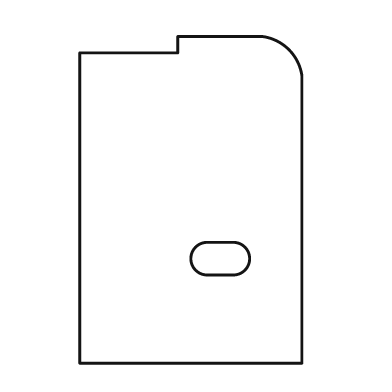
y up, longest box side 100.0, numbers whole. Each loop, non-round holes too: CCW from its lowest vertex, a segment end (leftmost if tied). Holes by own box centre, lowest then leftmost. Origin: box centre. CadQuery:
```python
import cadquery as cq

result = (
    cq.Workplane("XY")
    .moveTo(-34.0, -50.0)
    .lineTo(34.0, -50.0)
    .lineTo(34.0, 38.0)
    .threePointArc((30.0, 46.0), (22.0, 50.0))
    .lineTo(-4.0, 50.0)
    .lineTo(-4.0, 45.0)
    .lineTo(-34.0, 45.0)
    .close()
    .moveTo(5.0, -23.0)
    .lineTo(13.0, -23.0)
    .threePointArc((18.0, -18.0), (13.0, -13.0))
    .lineTo(5.0, -13.0)
    .threePointArc((0.0, -18.0), (5.0, -23.0))
    .close()
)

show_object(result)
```